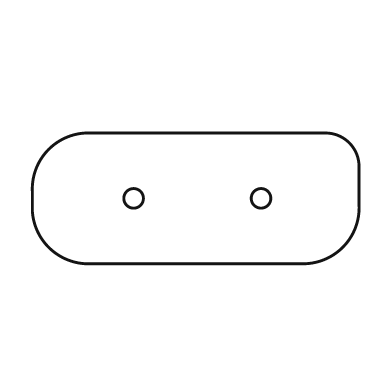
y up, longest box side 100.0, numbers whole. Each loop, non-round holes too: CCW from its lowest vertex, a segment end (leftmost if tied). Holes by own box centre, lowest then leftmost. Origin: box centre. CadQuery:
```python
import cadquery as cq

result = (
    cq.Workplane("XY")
    .moveTo(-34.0, -20.0)
    .lineTo(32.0, -20.0)
    .threePointArc((45.0, -15.0), (50.0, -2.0))
    .lineTo(50.0, 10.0)
    .threePointArc((47.0, 17.0), (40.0, 20.0))
    .lineTo(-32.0, 20.0)
    .threePointArc((-45.0, 15.0), (-50.0, 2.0))
    .lineTo(-50.0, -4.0)
    .threePointArc((-45.0, -15.0), (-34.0, -20.0))
    .close()
    .moveTo(-19.0, 0.0)
    .circle(3.0)
    .moveTo(20.0, 0.0)
    .circle(3.0)
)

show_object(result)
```